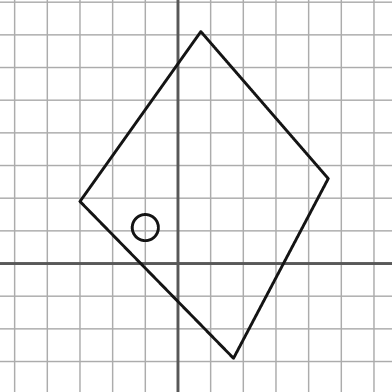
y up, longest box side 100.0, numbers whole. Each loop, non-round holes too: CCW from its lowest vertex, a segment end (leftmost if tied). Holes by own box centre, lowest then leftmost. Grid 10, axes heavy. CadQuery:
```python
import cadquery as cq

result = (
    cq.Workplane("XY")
    .moveTo(17.0, -29.0)
    .lineTo(46.0, 26.0)
    .lineTo(7.0, 71.0)
    .lineTo(-30.0, 19.0)
    .close()
    .moveTo(-10.0, 11.0)
    .circle(4.0)
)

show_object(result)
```